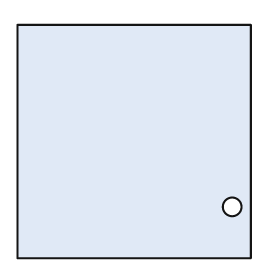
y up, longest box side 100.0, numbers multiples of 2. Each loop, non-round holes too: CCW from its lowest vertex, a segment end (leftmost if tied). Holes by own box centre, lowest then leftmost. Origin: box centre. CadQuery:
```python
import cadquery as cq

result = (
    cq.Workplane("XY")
    .moveTo(-50.0, -50.0)
    .lineTo(50.0, -50.0)
    .lineTo(50.0, 50.0)
    .lineTo(-50.0, 50.0)
    .close()
    .moveTo(42.0, -28.0)
    .circle(4.0)
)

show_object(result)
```